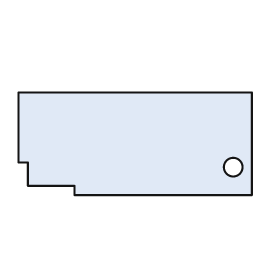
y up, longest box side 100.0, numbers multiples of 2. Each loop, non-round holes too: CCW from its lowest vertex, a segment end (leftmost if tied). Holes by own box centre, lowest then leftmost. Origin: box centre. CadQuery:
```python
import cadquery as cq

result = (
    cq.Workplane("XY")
    .moveTo(-26.0, -22.0)
    .lineTo(50.0, -22.0)
    .lineTo(50.0, 22.0)
    .lineTo(-50.0, 22.0)
    .lineTo(-50.0, -8.0)
    .lineTo(-46.0, -8.0)
    .lineTo(-46.0, -18.0)
    .lineTo(-26.0, -18.0)
    .close()
    .moveTo(42.0, -10.0)
    .circle(4.0)
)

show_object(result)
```